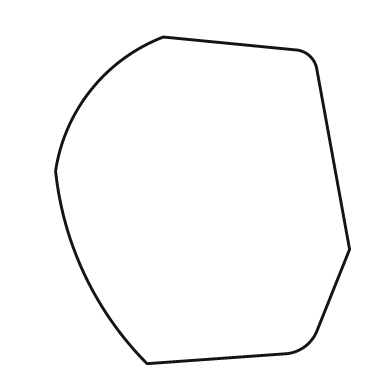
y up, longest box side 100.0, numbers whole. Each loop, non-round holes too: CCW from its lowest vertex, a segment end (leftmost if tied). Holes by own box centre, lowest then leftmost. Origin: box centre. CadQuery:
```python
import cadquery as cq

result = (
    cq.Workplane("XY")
    .moveTo(-17.0, -50.0)
    .lineTo(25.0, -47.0)
    .threePointArc((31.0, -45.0), (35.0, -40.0))
    .lineTo(45.0, -15.0)
    .lineTo(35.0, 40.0)
    .threePointArc((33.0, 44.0), (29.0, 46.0))
    .lineTo(-12.0, 50.0)
    .threePointArc((-34.0, 34.0), (-45.0, 9.0))
    .threePointArc((-36.0, -23.0), (-17.0, -50.0))
    .close()
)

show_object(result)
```